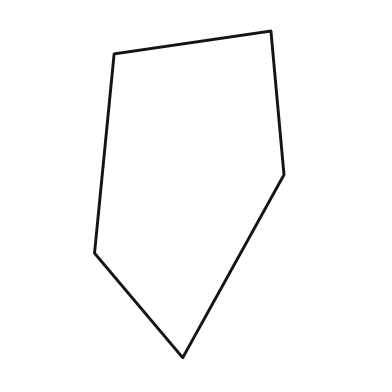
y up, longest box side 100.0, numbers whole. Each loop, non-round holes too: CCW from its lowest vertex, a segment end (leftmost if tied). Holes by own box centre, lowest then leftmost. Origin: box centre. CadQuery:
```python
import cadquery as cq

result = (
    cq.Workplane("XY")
    .moveTo(-2.0, -50.0)
    .lineTo(29.0, 6.0)
    .lineTo(25.0, 50.0)
    .lineTo(-23.0, 43.0)
    .lineTo(-29.0, -18.0)
    .close()
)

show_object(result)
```